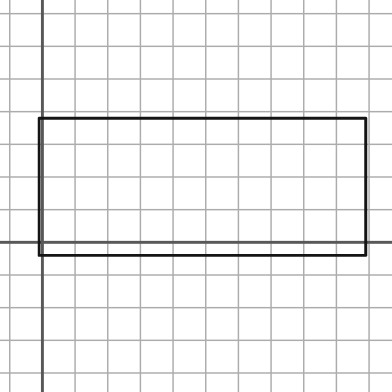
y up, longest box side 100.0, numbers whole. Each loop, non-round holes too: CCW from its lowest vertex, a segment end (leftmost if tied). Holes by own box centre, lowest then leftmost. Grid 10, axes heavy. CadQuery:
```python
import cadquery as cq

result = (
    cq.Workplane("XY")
    .moveTo(-1.0, -4.0)
    .lineTo(99.0, -4.0)
    .lineTo(99.0, 38.0)
    .lineTo(-1.0, 38.0)
    .close()
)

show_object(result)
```